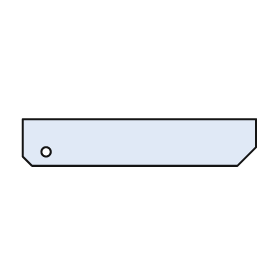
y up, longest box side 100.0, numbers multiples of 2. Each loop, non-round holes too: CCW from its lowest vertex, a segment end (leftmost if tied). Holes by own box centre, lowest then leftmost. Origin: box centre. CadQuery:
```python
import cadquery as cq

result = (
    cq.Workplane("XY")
    .moveTo(-46.0, -10.0)
    .lineTo(42.0, -10.0)
    .lineTo(50.0, -2.0)
    .lineTo(50.0, 10.0)
    .lineTo(-50.0, 10.0)
    .lineTo(-50.0, -6.0)
    .close()
    .moveTo(-40.0, -4.0)
    .circle(2.0)
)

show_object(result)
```